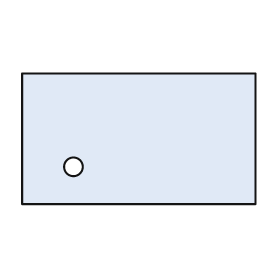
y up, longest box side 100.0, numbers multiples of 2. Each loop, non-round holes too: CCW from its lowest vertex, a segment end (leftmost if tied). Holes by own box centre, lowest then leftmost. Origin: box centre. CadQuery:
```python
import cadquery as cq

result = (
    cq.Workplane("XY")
    .moveTo(-50.0, -28.0)
    .lineTo(50.0, -28.0)
    .lineTo(50.0, 28.0)
    .lineTo(-50.0, 28.0)
    .close()
    .moveTo(-28.0, -12.0)
    .circle(4.0)
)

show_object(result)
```